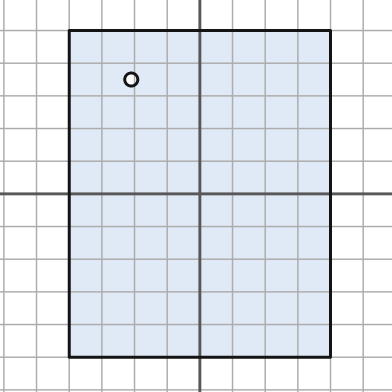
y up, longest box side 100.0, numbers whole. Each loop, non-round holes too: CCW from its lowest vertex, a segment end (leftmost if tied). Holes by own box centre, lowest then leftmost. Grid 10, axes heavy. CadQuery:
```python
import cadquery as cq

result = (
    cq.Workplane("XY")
    .moveTo(-40.0, -50.0)
    .lineTo(40.0, -50.0)
    .lineTo(40.0, 50.0)
    .lineTo(-40.0, 50.0)
    .close()
    .moveTo(-21.0, 35.0)
    .circle(2.0)
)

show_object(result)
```